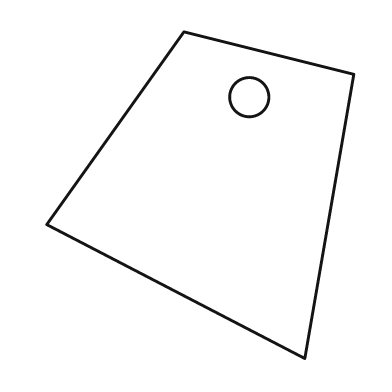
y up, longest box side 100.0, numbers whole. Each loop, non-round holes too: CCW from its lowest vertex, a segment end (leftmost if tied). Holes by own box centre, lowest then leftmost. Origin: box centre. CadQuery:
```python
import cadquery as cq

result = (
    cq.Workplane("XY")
    .moveTo(32.0, -50.0)
    .lineTo(47.0, 37.0)
    .lineTo(-5.0, 50.0)
    .lineTo(-47.0, -9.0)
    .close()
    .moveTo(15.0, 30.0)
    .circle(6.0)
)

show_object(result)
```